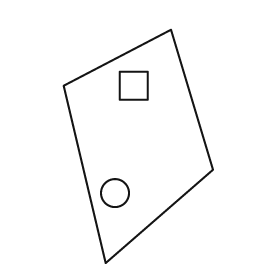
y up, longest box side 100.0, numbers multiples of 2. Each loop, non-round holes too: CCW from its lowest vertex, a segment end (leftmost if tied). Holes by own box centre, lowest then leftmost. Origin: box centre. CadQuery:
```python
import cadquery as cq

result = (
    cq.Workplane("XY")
    .moveTo(-14.0, -50.0)
    .lineTo(32.0, -10.0)
    .lineTo(14.0, 50.0)
    .lineTo(-32.0, 26.0)
    .close()
    .moveTo(-10.0, -20.0)
    .circle(6.0)
    .moveTo(-8.0, 20.0)
    .lineTo(4.0, 20.0)
    .lineTo(4.0, 32.0)
    .lineTo(-8.0, 32.0)
    .close()
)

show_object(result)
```